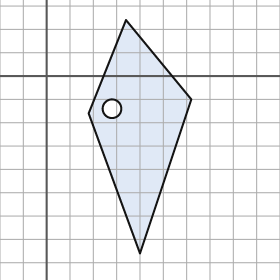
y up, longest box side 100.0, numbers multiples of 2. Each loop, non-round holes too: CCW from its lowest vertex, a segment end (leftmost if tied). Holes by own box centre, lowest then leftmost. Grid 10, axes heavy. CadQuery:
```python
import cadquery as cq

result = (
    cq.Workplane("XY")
    .moveTo(40.0, -76.0)
    .lineTo(62.0, -10.0)
    .lineTo(34.0, 24.0)
    .lineTo(18.0, -16.0)
    .close()
    .moveTo(28.0, -14.0)
    .circle(4.0)
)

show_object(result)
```